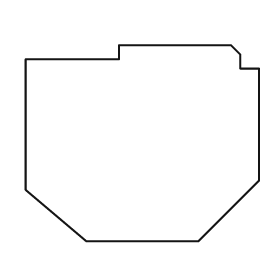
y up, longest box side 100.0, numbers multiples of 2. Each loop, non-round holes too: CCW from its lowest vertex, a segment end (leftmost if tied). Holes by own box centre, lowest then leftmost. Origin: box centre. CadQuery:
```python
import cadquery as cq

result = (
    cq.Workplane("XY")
    .moveTo(-24.0, -42.0)
    .lineTo(24.0, -42.0)
    .lineTo(50.0, -16.0)
    .lineTo(50.0, 32.0)
    .lineTo(42.0, 32.0)
    .lineTo(42.0, 38.0)
    .lineTo(38.0, 42.0)
    .lineTo(-10.0, 42.0)
    .lineTo(-10.0, 36.0)
    .lineTo(-50.0, 36.0)
    .lineTo(-50.0, -20.0)
    .close()
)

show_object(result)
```